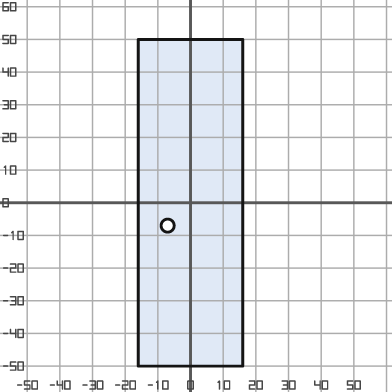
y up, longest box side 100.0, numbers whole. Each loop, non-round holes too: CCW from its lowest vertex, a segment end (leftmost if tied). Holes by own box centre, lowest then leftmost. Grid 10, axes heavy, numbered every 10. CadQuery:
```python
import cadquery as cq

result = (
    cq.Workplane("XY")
    .moveTo(-16.0, -50.0)
    .lineTo(16.0, -50.0)
    .lineTo(16.0, 50.0)
    .lineTo(-16.0, 50.0)
    .close()
    .moveTo(-7.0, -7.0)
    .circle(2.0)
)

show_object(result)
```